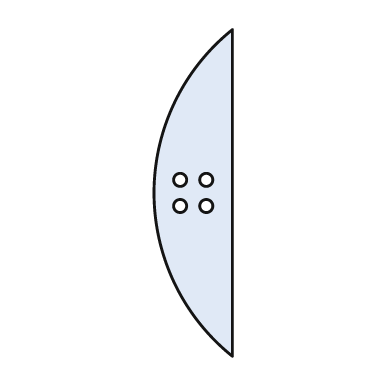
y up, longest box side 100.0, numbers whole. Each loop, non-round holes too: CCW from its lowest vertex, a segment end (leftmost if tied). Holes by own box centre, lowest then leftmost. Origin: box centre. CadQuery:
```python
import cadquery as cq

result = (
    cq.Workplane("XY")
    .moveTo(12.0, -50.0)
    .lineTo(12.0, 50.0)
    .threePointArc((-12.0, 0.0), (12.0, -50.0))
    .close()
    .moveTo(-4.0, -4.0)
    .circle(2.0)
    .moveTo(4.0, -4.0)
    .circle(2.0)
    .moveTo(-4.0, 4.0)
    .circle(2.0)
    .moveTo(4.0, 4.0)
    .circle(2.0)
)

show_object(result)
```